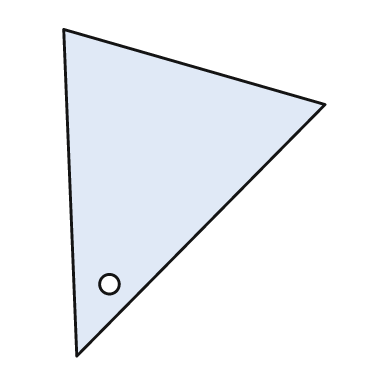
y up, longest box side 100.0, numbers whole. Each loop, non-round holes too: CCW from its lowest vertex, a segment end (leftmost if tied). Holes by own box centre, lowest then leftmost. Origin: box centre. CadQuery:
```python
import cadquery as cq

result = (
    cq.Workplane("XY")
    .moveTo(-36.0, -50.0)
    .lineTo(40.0, 27.0)
    .lineTo(-40.0, 50.0)
    .close()
    .moveTo(-26.0, -28.0)
    .circle(3.0)
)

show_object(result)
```